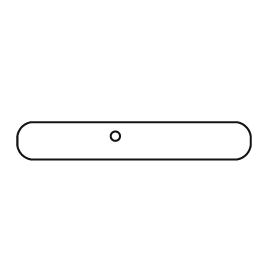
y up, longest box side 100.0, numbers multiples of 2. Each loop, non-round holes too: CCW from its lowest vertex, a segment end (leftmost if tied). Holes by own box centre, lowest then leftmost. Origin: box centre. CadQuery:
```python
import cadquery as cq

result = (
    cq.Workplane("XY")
    .moveTo(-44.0, -8.0)
    .lineTo(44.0, -8.0)
    .threePointArc((48.0, -6.0), (50.0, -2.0))
    .lineTo(50.0, 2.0)
    .threePointArc((48.0, 6.0), (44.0, 8.0))
    .lineTo(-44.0, 8.0)
    .threePointArc((-48.0, 6.0), (-50.0, 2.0))
    .lineTo(-50.0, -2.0)
    .threePointArc((-48.0, -6.0), (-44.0, -8.0))
    .close()
    .moveTo(-8.0, 2.0)
    .circle(2.0)
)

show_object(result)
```